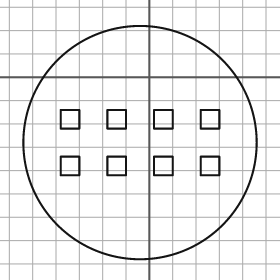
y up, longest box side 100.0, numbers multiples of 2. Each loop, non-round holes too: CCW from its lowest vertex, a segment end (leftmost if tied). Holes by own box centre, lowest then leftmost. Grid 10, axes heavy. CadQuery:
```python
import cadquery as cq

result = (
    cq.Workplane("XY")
    .moveTo(-4.0, -28.0)
    .circle(50.0)
    .moveTo(-38.0, -42.0)
    .lineTo(-30.0, -42.0)
    .lineTo(-30.0, -34.0)
    .lineTo(-38.0, -34.0)
    .close()
    .moveTo(-18.0, -42.0)
    .lineTo(-10.0, -42.0)
    .lineTo(-10.0, -34.0)
    .lineTo(-18.0, -34.0)
    .close()
    .moveTo(2.0, -42.0)
    .lineTo(10.0, -42.0)
    .lineTo(10.0, -34.0)
    .lineTo(2.0, -34.0)
    .close()
    .moveTo(22.0, -42.0)
    .lineTo(30.0, -42.0)
    .lineTo(30.0, -34.0)
    .lineTo(22.0, -34.0)
    .close()
    .moveTo(-38.0, -22.0)
    .lineTo(-30.0, -22.0)
    .lineTo(-30.0, -14.0)
    .lineTo(-38.0, -14.0)
    .close()
    .moveTo(-18.0, -22.0)
    .lineTo(-10.0, -22.0)
    .lineTo(-10.0, -14.0)
    .lineTo(-18.0, -14.0)
    .close()
    .moveTo(2.0, -22.0)
    .lineTo(10.0, -22.0)
    .lineTo(10.0, -14.0)
    .lineTo(2.0, -14.0)
    .close()
    .moveTo(22.0, -22.0)
    .lineTo(30.0, -22.0)
    .lineTo(30.0, -14.0)
    .lineTo(22.0, -14.0)
    .close()
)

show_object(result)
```